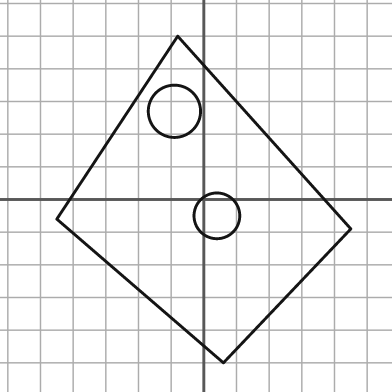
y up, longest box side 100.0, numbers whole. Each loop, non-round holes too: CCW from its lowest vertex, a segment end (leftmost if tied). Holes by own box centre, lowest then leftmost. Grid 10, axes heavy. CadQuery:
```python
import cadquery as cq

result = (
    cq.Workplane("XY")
    .moveTo(6.0, -50.0)
    .lineTo(45.0, -9.0)
    .lineTo(-8.0, 50.0)
    .lineTo(-45.0, -6.0)
    .close()
    .moveTo(4.0, -5.0)
    .circle(7.0)
    .moveTo(-9.0, 27.0)
    .circle(8.0)
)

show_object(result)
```